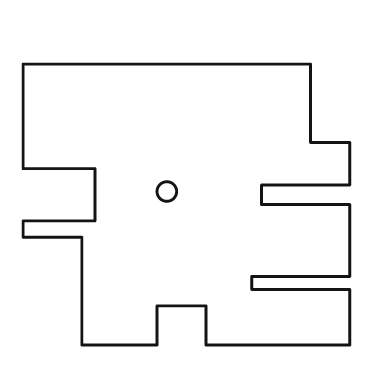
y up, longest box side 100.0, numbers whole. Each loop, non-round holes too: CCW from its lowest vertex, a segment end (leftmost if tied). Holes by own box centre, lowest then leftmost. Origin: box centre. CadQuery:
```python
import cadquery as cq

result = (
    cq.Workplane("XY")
    .moveTo(-32.0, -43.0)
    .lineTo(-9.0, -43.0)
    .lineTo(-9.0, -31.0)
    .lineTo(6.0, -31.0)
    .lineTo(6.0, -43.0)
    .lineTo(50.0, -43.0)
    .lineTo(50.0, -26.0)
    .lineTo(20.0, -26.0)
    .lineTo(20.0, -22.0)
    .lineTo(50.0, -22.0)
    .lineTo(50.0, 0.0)
    .lineTo(23.0, 0.0)
    .lineTo(23.0, 6.0)
    .lineTo(50.0, 6.0)
    .lineTo(50.0, 19.0)
    .lineTo(38.0, 19.0)
    .lineTo(38.0, 43.0)
    .lineTo(-50.0, 43.0)
    .lineTo(-50.0, 11.0)
    .lineTo(-28.0, 11.0)
    .lineTo(-28.0, -5.0)
    .lineTo(-50.0, -5.0)
    .lineTo(-50.0, -10.0)
    .lineTo(-32.0, -10.0)
    .close()
    .moveTo(-6.0, 4.0)
    .circle(3.0)
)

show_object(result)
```